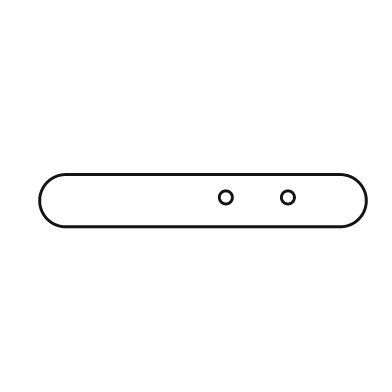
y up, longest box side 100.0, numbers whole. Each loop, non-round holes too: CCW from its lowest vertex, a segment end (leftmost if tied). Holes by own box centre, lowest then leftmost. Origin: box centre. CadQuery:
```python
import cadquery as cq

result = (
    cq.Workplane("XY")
    .moveTo(-42.0, -8.0)
    .lineTo(42.0, -8.0)
    .threePointArc((50.0, 0.0), (42.0, 8.0))
    .lineTo(-42.0, 8.0)
    .threePointArc((-50.0, 0.0), (-42.0, -8.0))
    .close()
    .moveTo(7.0, 1.0)
    .circle(2.0)
    .moveTo(26.0, 1.0)
    .circle(2.0)
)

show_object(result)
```